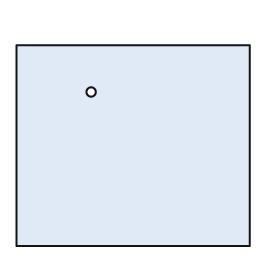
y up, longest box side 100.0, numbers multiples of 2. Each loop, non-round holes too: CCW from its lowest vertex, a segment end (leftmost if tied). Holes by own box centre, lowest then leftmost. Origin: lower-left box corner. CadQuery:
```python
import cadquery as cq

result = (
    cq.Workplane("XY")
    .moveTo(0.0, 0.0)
    .lineTo(100.0, 0.0)
    .lineTo(100.0, 86.0)
    .lineTo(0.0, 86.0)
    .close()
    .moveTo(32.0, 66.0)
    .circle(2.0)
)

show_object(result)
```